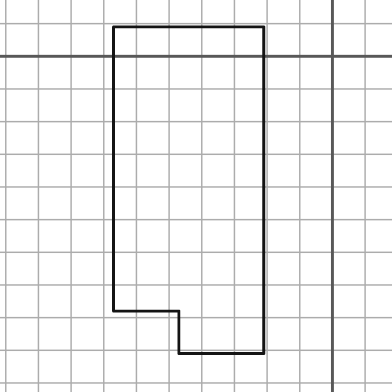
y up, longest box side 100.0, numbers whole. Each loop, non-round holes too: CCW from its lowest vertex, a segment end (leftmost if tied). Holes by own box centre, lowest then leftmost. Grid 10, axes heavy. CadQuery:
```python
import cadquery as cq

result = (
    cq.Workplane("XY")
    .moveTo(-47.0, -91.0)
    .lineTo(-21.0, -91.0)
    .lineTo(-21.0, 9.0)
    .lineTo(-67.0, 9.0)
    .lineTo(-67.0, -78.0)
    .lineTo(-47.0, -78.0)
    .close()
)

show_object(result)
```